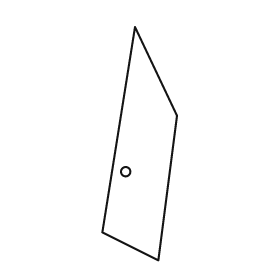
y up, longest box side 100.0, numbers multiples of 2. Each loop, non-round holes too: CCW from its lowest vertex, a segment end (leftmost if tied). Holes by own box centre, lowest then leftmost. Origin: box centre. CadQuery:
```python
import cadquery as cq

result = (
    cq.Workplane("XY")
    .moveTo(8.0, -50.0)
    .lineTo(16.0, 12.0)
    .lineTo(-2.0, 50.0)
    .lineTo(-16.0, -38.0)
    .close()
    .moveTo(-6.0, -12.0)
    .circle(2.0)
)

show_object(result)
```